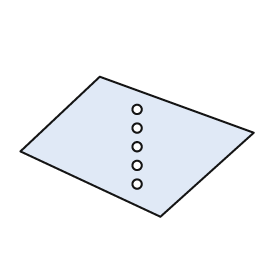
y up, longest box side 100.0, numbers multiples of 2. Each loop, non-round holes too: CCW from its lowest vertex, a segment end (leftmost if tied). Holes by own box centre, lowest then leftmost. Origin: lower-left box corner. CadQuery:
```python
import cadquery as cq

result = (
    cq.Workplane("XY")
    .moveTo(60.0, 0.0)
    .lineTo(100.0, 36.0)
    .lineTo(34.0, 60.0)
    .lineTo(0.0, 28.0)
    .close()
    .moveTo(50.0, 14.0)
    .circle(2.0)
    .moveTo(50.0, 22.0)
    .circle(2.0)
    .moveTo(50.0, 30.0)
    .circle(2.0)
    .moveTo(50.0, 38.0)
    .circle(2.0)
    .moveTo(50.0, 46.0)
    .circle(2.0)
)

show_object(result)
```